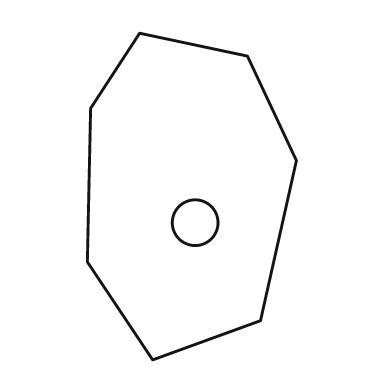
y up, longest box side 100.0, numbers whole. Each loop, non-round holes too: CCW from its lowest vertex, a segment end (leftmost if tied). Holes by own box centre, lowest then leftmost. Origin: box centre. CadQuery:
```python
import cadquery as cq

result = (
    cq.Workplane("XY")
    .moveTo(-12.0, -50.0)
    .lineTo(21.0, -38.0)
    .lineTo(32.0, 11.0)
    .lineTo(17.0, 43.0)
    .lineTo(-16.0, 50.0)
    .lineTo(-31.0, 27.0)
    .lineTo(-32.0, -20.0)
    .close()
    .moveTo(1.0, -8.0)
    .circle(7.0)
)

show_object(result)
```